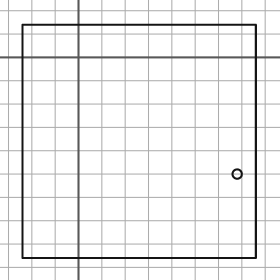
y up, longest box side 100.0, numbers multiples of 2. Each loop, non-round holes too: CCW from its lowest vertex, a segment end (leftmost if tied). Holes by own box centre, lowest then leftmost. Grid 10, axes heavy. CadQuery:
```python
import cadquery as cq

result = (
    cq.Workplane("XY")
    .moveTo(-24.0, -86.0)
    .lineTo(76.0, -86.0)
    .lineTo(76.0, 14.0)
    .lineTo(-24.0, 14.0)
    .close()
    .moveTo(68.0, -50.0)
    .circle(2.0)
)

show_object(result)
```